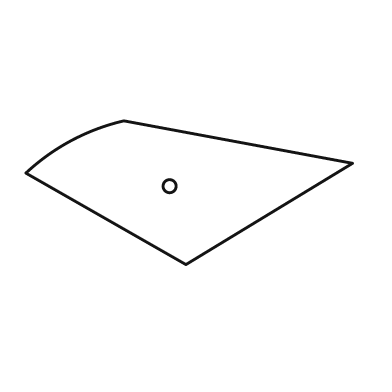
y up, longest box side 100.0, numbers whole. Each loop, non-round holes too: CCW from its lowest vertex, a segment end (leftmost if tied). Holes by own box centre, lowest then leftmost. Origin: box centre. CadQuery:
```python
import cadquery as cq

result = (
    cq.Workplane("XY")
    .moveTo(-1.0, -22.0)
    .lineTo(50.0, 9.0)
    .lineTo(-20.0, 22.0)
    .threePointArc((-36.0, 16.0), (-50.0, 6.0))
    .close()
    .moveTo(-6.0, 2.0)
    .circle(2.0)
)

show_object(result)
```